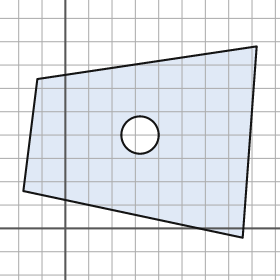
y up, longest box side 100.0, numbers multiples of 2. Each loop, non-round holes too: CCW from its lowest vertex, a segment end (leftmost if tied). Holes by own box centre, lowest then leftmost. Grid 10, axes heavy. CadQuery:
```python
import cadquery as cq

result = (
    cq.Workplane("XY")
    .moveTo(76.0, -4.0)
    .lineTo(82.0, 78.0)
    .lineTo(-12.0, 64.0)
    .lineTo(-18.0, 16.0)
    .close()
    .moveTo(32.0, 40.0)
    .circle(8.0)
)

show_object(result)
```